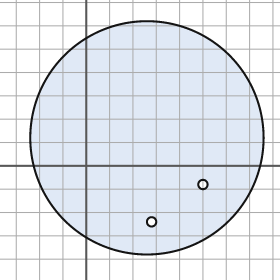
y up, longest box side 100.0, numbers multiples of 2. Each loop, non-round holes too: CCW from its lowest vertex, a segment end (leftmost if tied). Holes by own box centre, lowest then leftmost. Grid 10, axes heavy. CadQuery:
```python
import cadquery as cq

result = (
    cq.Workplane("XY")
    .moveTo(26.0, 12.0)
    .circle(50.0)
    .moveTo(28.0, -24.0)
    .circle(2.0)
    .moveTo(50.0, -8.0)
    .circle(2.0)
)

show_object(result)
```